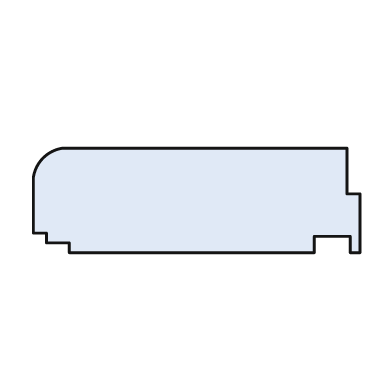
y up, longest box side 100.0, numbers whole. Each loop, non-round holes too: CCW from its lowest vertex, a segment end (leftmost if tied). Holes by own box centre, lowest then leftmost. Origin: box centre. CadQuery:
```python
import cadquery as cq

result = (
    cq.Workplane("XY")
    .moveTo(-39.0, -16.0)
    .lineTo(36.0, -16.0)
    .lineTo(36.0, -11.0)
    .lineTo(47.0, -11.0)
    .lineTo(47.0, -16.0)
    .lineTo(50.0, -16.0)
    .lineTo(50.0, 2.0)
    .lineTo(46.0, 2.0)
    .lineTo(46.0, 16.0)
    .lineTo(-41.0, 16.0)
    .threePointArc((-47.0, 13.0), (-50.0, 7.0))
    .lineTo(-50.0, -10.0)
    .lineTo(-46.0, -10.0)
    .lineTo(-46.0, -13.0)
    .lineTo(-39.0, -13.0)
    .close()
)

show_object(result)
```